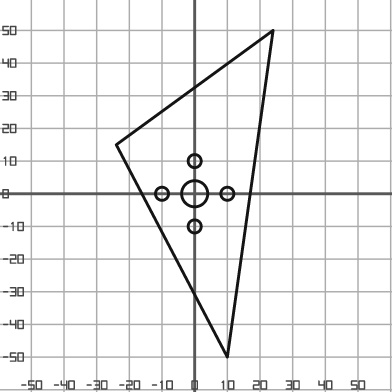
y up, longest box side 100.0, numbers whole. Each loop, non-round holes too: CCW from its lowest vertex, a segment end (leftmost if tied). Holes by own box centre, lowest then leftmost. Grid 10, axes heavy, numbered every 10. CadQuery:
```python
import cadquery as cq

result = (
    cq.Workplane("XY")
    .moveTo(10.0, -50.0)
    .lineTo(24.0, 50.0)
    .lineTo(-24.0, 15.0)
    .close()
    .moveTo(0.0, -10.0)
    .circle(2.0)
    .moveTo(-10.0, 0.0)
    .circle(2.0)
    .moveTo(0.0, 0.0)
    .circle(4.0)
    .moveTo(10.0, 0.0)
    .circle(2.0)
    .moveTo(0.0, 10.0)
    .circle(2.0)
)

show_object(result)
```